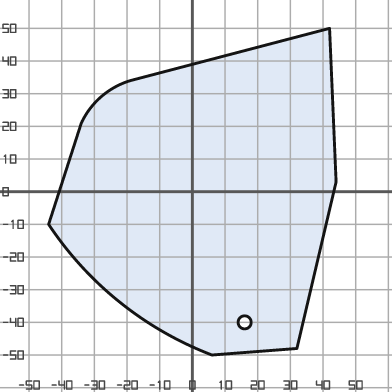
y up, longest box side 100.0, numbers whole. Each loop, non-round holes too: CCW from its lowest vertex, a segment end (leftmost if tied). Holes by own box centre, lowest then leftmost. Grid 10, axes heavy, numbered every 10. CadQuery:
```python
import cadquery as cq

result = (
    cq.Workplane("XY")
    .moveTo(6.0, -50.0)
    .lineTo(32.0, -48.0)
    .lineTo(44.0, 3.0)
    .lineTo(42.0, 50.0)
    .lineTo(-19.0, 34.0)
    .threePointArc((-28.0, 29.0), (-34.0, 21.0))
    .lineTo(-44.0, -10.0)
    .threePointArc((-22.0, -34.0), (6.0, -50.0))
    .close()
    .moveTo(16.0, -40.0)
    .circle(2.0)
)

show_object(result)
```